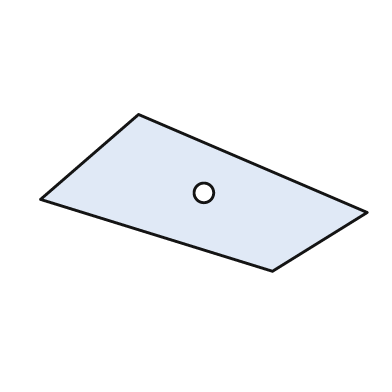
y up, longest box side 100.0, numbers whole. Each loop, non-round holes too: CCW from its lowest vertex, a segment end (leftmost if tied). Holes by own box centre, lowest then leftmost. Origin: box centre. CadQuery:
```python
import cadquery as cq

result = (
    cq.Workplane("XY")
    .moveTo(21.0, -24.0)
    .lineTo(50.0, -6.0)
    .lineTo(-20.0, 24.0)
    .lineTo(-50.0, -2.0)
    .close()
    .moveTo(0.0, 0.0)
    .circle(3.0)
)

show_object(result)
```